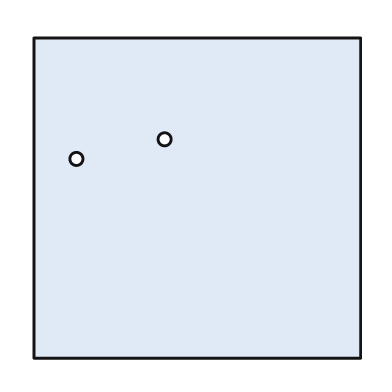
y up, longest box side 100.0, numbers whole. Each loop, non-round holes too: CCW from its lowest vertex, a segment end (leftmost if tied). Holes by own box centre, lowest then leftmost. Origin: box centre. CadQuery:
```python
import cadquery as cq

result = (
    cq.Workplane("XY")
    .moveTo(-50.0, -49.0)
    .lineTo(50.0, -49.0)
    .lineTo(50.0, 49.0)
    .lineTo(-50.0, 49.0)
    .close()
    .moveTo(-37.0, 12.0)
    .circle(2.0)
    .moveTo(-10.0, 18.0)
    .circle(2.0)
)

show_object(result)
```